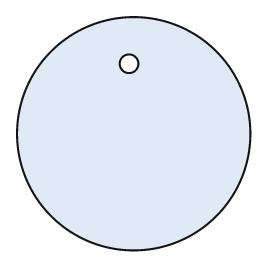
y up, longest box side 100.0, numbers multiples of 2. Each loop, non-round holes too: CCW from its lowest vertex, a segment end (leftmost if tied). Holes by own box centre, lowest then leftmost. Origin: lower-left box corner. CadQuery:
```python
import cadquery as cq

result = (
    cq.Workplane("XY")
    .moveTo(50.0, 50.0)
    .circle(50.0)
    .moveTo(48.0, 80.0)
    .circle(4.0)
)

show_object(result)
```